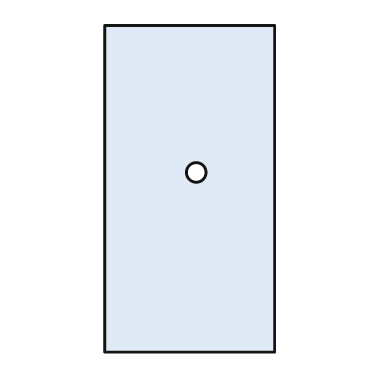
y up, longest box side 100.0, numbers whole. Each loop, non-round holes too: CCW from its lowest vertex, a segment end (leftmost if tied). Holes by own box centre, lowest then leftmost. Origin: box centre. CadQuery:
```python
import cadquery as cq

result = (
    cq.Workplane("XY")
    .moveTo(-26.0, -50.0)
    .lineTo(26.0, -50.0)
    .lineTo(26.0, 50.0)
    .lineTo(-26.0, 50.0)
    .close()
    .moveTo(2.0, 5.0)
    .circle(3.0)
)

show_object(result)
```